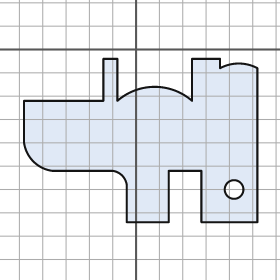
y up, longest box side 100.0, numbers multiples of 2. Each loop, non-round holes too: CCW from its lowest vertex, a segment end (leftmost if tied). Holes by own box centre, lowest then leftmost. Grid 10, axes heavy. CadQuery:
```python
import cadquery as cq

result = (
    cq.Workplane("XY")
    .moveTo(-4.0, -74.0)
    .lineTo(14.0, -74.0)
    .lineTo(14.0, -52.0)
    .lineTo(28.0, -52.0)
    .lineTo(28.0, -74.0)
    .lineTo(52.0, -74.0)
    .lineTo(52.0, -8.0)
    .threePointArc((44.0, -6.0), (36.0, -8.0))
    .lineTo(36.0, -4.0)
    .lineTo(24.0, -4.0)
    .lineTo(24.0, -22.0)
    .threePointArc((8.0, -16.0), (-8.0, -22.0))
    .lineTo(-8.0, -4.0)
    .lineTo(-14.0, -4.0)
    .lineTo(-14.0, -22.0)
    .lineTo(-48.0, -22.0)
    .lineTo(-48.0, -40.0)
    .threePointArc((-44.0, -48.0), (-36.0, -52.0))
    .lineTo(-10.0, -52.0)
    .threePointArc((-6.0, -54.0), (-4.0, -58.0))
    .close()
    .moveTo(42.0, -60.0)
    .circle(4.0)
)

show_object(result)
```